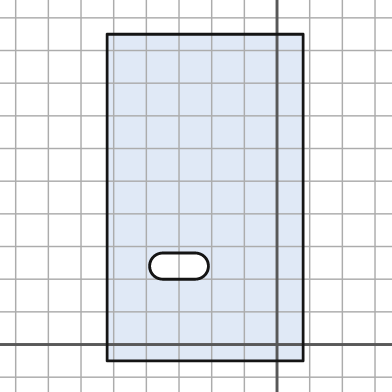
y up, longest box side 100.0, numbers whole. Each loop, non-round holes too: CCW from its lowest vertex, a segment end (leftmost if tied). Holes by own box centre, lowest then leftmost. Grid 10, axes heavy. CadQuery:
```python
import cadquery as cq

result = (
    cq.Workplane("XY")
    .moveTo(-52.0, -5.0)
    .lineTo(8.0, -5.0)
    .lineTo(8.0, 95.0)
    .lineTo(-52.0, 95.0)
    .close()
    .moveTo(-35.0, 20.0)
    .lineTo(-25.0, 20.0)
    .threePointArc((-21.0, 24.0), (-25.0, 28.0))
    .lineTo(-35.0, 28.0)
    .threePointArc((-39.0, 24.0), (-35.0, 20.0))
    .close()
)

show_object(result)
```